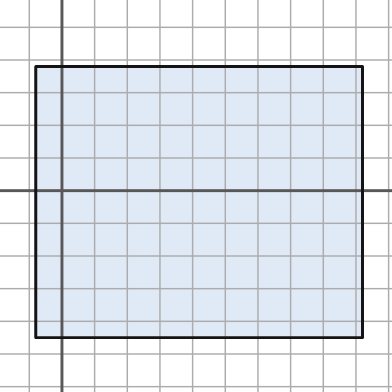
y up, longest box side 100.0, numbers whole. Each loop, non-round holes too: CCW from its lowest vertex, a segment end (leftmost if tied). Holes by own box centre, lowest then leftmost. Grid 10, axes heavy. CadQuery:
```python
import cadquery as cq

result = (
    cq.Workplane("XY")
    .moveTo(-8.0, -45.0)
    .lineTo(92.0, -45.0)
    .lineTo(92.0, 38.0)
    .lineTo(-8.0, 38.0)
    .close()
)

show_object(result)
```